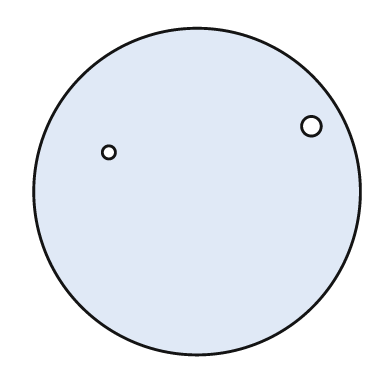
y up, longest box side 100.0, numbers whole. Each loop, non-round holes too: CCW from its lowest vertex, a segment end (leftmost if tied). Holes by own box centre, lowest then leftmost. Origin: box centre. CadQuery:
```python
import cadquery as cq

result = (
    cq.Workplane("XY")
    .moveTo(0.0, 0.0)
    .circle(50.0)
    .moveTo(-27.0, 12.0)
    .circle(2.0)
    .moveTo(35.0, 20.0)
    .circle(3.0)
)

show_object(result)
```